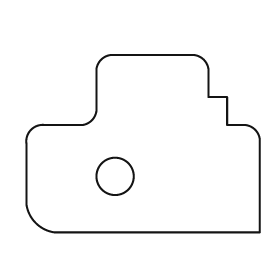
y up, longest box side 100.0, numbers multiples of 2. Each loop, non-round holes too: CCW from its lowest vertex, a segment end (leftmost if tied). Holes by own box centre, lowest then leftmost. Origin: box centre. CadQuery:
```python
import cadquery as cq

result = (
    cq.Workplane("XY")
    .moveTo(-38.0, -38.0)
    .lineTo(50.0, -38.0)
    .lineTo(50.0, 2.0)
    .threePointArc((48.0, 6.0), (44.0, 8.0))
    .lineTo(36.0, 8.0)
    .lineTo(36.0, 20.0)
    .lineTo(28.0, 20.0)
    .lineTo(28.0, 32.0)
    .threePointArc((26.0, 36.0), (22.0, 38.0))
    .lineTo(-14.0, 38.0)
    .threePointArc((-18.0, 36.0), (-20.0, 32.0))
    .lineTo(-20.0, 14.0)
    .threePointArc((-22.0, 10.0), (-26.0, 8.0))
    .lineTo(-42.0, 8.0)
    .threePointArc((-48.0, 6.0), (-50.0, 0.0))
    .lineTo(-50.0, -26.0)
    .threePointArc((-46.0, -34.0), (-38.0, -38.0))
    .close()
    .moveTo(-12.0, -14.0)
    .circle(8.0)
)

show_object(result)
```